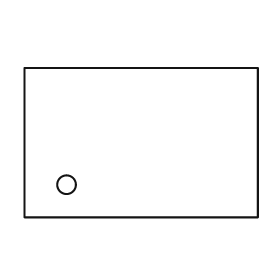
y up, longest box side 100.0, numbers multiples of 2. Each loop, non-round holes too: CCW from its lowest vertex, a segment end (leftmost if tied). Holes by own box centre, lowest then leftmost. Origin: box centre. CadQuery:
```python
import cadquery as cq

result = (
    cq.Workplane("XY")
    .moveTo(-50.0, -32.0)
    .lineTo(50.0, -32.0)
    .lineTo(50.0, 32.0)
    .lineTo(-50.0, 32.0)
    .close()
    .moveTo(-32.0, -18.0)
    .circle(4.0)
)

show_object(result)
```